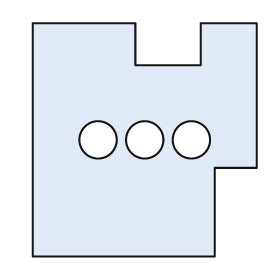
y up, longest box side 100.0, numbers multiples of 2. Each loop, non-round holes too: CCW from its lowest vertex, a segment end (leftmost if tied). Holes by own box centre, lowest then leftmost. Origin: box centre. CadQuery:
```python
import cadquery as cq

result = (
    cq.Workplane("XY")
    .moveTo(-48.0, -50.0)
    .lineTo(30.0, -50.0)
    .lineTo(30.0, -12.0)
    .lineTo(48.0, -12.0)
    .lineTo(48.0, 50.0)
    .lineTo(24.0, 50.0)
    .lineTo(24.0, 32.0)
    .lineTo(-4.0, 32.0)
    .lineTo(-4.0, 50.0)
    .lineTo(-48.0, 50.0)
    .close()
    .moveTo(-20.0, 0.0)
    .circle(8.0)
    .moveTo(0.0, 0.0)
    .circle(8.0)
    .moveTo(20.0, 0.0)
    .circle(8.0)
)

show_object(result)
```